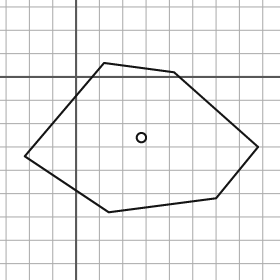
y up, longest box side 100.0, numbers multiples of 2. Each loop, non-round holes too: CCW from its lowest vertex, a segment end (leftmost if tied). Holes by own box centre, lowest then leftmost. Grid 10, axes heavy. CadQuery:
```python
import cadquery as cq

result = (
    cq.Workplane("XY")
    .moveTo(14.0, -58.0)
    .lineTo(60.0, -52.0)
    .lineTo(78.0, -30.0)
    .lineTo(42.0, 2.0)
    .lineTo(12.0, 6.0)
    .lineTo(-22.0, -34.0)
    .close()
    .moveTo(28.0, -26.0)
    .circle(2.0)
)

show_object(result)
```